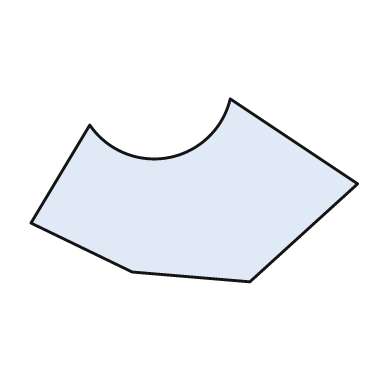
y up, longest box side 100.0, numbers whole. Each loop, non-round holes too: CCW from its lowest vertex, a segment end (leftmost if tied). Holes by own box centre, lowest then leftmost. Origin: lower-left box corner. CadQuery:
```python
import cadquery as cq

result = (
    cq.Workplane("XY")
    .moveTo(67.0, 0.0)
    .lineTo(100.0, 30.0)
    .lineTo(61.0, 56.0)
    .threePointArc((42.0, 38.0), (18.0, 48.0))
    .lineTo(0.0, 18.0)
    .lineTo(31.0, 3.0)
    .close()
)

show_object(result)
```